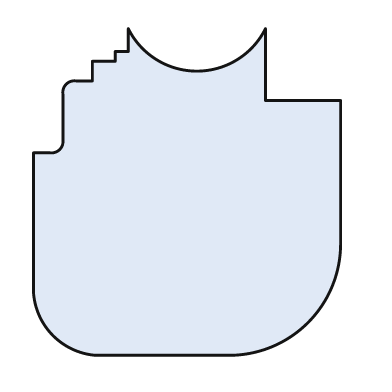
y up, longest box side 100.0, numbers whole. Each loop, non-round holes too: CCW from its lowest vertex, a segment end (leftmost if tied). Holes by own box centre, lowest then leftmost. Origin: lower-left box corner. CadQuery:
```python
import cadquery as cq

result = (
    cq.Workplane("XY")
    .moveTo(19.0, 0.0)
    .lineTo(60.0, 0.0)
    .threePointArc((84.0, 10.0), (94.0, 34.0))
    .lineTo(94.0, 78.0)
    .lineTo(71.0, 78.0)
    .lineTo(71.0, 100.0)
    .threePointArc((50.0, 87.0), (29.0, 100.0))
    .lineTo(29.0, 93.0)
    .lineTo(25.0, 93.0)
    .lineTo(25.0, 90.0)
    .lineTo(18.0, 90.0)
    .lineTo(18.0, 84.0)
    .lineTo(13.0, 84.0)
    .threePointArc((10.0, 83.0), (9.0, 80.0))
    .lineTo(9.0, 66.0)
    .threePointArc((8.0, 63.0), (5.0, 62.0))
    .lineTo(0.0, 62.0)
    .lineTo(0.0, 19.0)
    .threePointArc((6.0, 6.0), (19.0, 0.0))
    .close()
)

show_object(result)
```